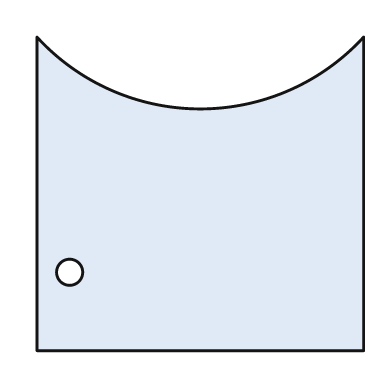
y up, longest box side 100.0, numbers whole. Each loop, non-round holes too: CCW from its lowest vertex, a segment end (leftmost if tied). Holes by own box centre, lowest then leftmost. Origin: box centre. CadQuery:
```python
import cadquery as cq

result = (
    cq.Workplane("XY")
    .moveTo(-50.0, -48.0)
    .lineTo(50.0, -48.0)
    .lineTo(50.0, 48.0)
    .threePointArc((0.0, 26.0), (-50.0, 48.0))
    .close()
    .moveTo(-40.0, -24.0)
    .circle(4.0)
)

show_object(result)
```